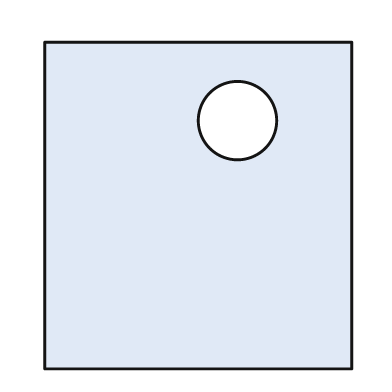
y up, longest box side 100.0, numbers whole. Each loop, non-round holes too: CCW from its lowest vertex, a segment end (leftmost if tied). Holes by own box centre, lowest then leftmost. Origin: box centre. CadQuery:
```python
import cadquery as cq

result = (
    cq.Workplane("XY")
    .moveTo(-47.0, -50.0)
    .lineTo(47.0, -50.0)
    .lineTo(47.0, 50.0)
    .lineTo(-47.0, 50.0)
    .close()
    .moveTo(12.0, 26.0)
    .circle(12.0)
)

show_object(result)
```